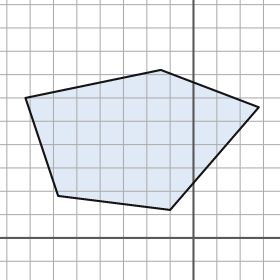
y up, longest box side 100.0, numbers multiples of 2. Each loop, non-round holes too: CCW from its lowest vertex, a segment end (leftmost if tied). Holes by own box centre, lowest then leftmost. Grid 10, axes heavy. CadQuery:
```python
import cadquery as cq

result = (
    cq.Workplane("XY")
    .moveTo(-10.0, 12.0)
    .lineTo(28.0, 56.0)
    .lineTo(-14.0, 72.0)
    .lineTo(-72.0, 60.0)
    .lineTo(-58.0, 18.0)
    .close()
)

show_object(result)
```